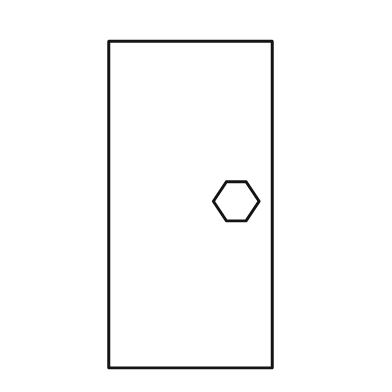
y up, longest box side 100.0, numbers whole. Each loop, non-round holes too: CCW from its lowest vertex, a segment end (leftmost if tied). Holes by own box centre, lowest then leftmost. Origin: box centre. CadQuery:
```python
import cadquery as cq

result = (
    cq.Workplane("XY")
    .moveTo(-25.0, -50.0)
    .lineTo(25.0, -50.0)
    .lineTo(25.0, 50.0)
    .lineTo(-25.0, 50.0)
    .close()
    .moveTo(11.0, -5.0)
    .lineTo(17.0, -5.0)
    .lineTo(21.0, 1.0)
    .lineTo(17.0, 7.0)
    .lineTo(11.0, 7.0)
    .lineTo(7.0, 1.0)
    .close()
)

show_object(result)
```